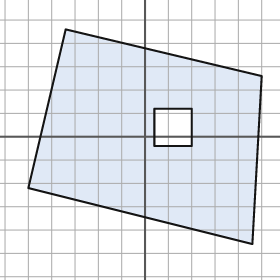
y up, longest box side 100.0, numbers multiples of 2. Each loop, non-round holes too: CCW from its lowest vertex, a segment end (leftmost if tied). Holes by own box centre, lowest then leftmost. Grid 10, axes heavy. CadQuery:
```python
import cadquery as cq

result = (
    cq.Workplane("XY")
    .moveTo(46.0, -46.0)
    .lineTo(50.0, 26.0)
    .lineTo(-34.0, 46.0)
    .lineTo(-50.0, -22.0)
    .close()
    .moveTo(4.0, -4.0)
    .lineTo(20.0, -4.0)
    .lineTo(20.0, 12.0)
    .lineTo(4.0, 12.0)
    .close()
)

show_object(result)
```